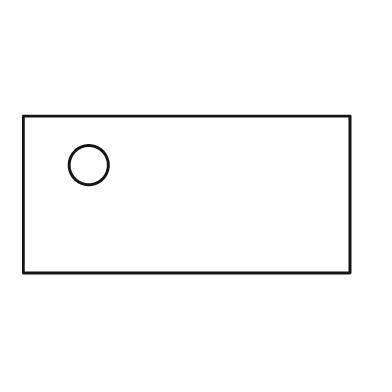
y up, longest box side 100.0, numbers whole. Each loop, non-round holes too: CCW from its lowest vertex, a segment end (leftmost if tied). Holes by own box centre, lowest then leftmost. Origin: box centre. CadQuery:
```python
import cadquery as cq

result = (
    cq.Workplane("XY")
    .moveTo(-50.0, -24.0)
    .lineTo(50.0, -24.0)
    .lineTo(50.0, 24.0)
    .lineTo(-50.0, 24.0)
    .close()
    .moveTo(-30.0, 9.0)
    .circle(6.0)
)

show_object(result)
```